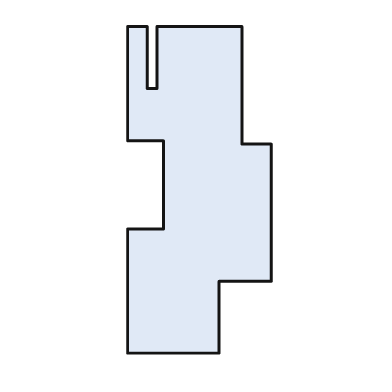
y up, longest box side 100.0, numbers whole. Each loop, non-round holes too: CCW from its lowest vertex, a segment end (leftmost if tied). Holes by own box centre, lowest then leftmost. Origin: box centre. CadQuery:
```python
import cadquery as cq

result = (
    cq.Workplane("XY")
    .moveTo(-22.0, -50.0)
    .lineTo(6.0, -50.0)
    .lineTo(6.0, -28.0)
    .lineTo(22.0, -28.0)
    .lineTo(22.0, 14.0)
    .lineTo(13.0, 14.0)
    .lineTo(13.0, 50.0)
    .lineTo(-13.0, 50.0)
    .lineTo(-13.0, 31.0)
    .lineTo(-16.0, 31.0)
    .lineTo(-16.0, 50.0)
    .lineTo(-22.0, 50.0)
    .lineTo(-22.0, 15.0)
    .lineTo(-11.0, 15.0)
    .lineTo(-11.0, -12.0)
    .lineTo(-22.0, -12.0)
    .close()
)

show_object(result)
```